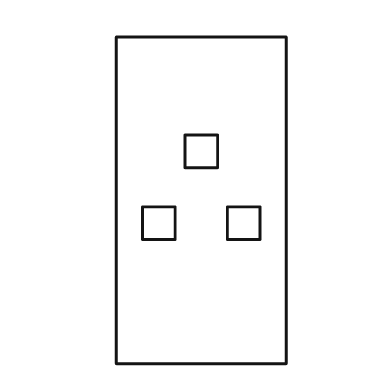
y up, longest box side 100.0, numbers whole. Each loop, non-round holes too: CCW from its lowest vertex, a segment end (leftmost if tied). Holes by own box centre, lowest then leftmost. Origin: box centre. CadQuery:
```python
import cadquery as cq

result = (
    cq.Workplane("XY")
    .moveTo(-26.0, -50.0)
    .lineTo(26.0, -50.0)
    .lineTo(26.0, 50.0)
    .lineTo(-26.0, 50.0)
    .close()
    .moveTo(-18.0, -12.0)
    .lineTo(-8.0, -12.0)
    .lineTo(-8.0, -2.0)
    .lineTo(-18.0, -2.0)
    .close()
    .moveTo(8.0, -12.0)
    .lineTo(18.0, -12.0)
    .lineTo(18.0, -2.0)
    .lineTo(8.0, -2.0)
    .close()
    .moveTo(-5.0, 10.0)
    .lineTo(5.0, 10.0)
    .lineTo(5.0, 20.0)
    .lineTo(-5.0, 20.0)
    .close()
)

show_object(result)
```